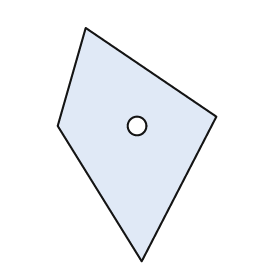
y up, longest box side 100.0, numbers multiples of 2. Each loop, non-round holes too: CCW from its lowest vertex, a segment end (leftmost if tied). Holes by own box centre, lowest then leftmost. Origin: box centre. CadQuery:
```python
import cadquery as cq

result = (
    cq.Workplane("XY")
    .moveTo(2.0, -50.0)
    .lineTo(34.0, 12.0)
    .lineTo(-22.0, 50.0)
    .lineTo(-34.0, 8.0)
    .close()
    .moveTo(0.0, 8.0)
    .circle(4.0)
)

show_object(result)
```